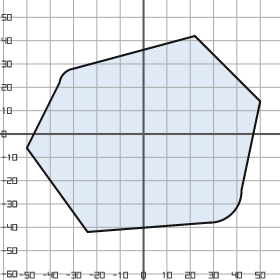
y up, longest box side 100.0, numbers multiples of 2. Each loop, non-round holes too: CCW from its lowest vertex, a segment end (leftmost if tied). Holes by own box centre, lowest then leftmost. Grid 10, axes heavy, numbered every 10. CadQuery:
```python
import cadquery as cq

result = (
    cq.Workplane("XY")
    .moveTo(-24.0, -42.0)
    .lineTo(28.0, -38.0)
    .threePointArc((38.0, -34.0), (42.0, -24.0))
    .lineTo(50.0, 14.0)
    .lineTo(22.0, 42.0)
    .lineTo(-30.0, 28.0)
    .threePointArc((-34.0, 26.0), (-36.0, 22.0))
    .lineTo(-50.0, -6.0)
    .close()
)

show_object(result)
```